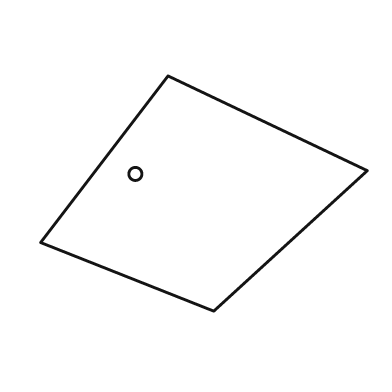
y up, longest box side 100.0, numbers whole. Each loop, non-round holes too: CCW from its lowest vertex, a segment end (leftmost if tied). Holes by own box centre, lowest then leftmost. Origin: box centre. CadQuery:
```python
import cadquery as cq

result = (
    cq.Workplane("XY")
    .moveTo(3.0, -36.0)
    .lineTo(50.0, 7.0)
    .lineTo(-11.0, 36.0)
    .lineTo(-50.0, -15.0)
    .close()
    .moveTo(-21.0, 6.0)
    .circle(2.0)
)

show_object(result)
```